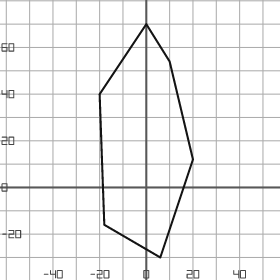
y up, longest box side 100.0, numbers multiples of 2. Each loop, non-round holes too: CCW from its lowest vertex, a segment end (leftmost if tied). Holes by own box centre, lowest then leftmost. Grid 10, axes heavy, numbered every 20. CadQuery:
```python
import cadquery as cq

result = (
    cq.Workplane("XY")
    .moveTo(6.0, -30.0)
    .lineTo(20.0, 12.0)
    .lineTo(10.0, 54.0)
    .lineTo(0.0, 70.0)
    .lineTo(-20.0, 40.0)
    .lineTo(-18.0, -16.0)
    .close()
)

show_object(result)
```